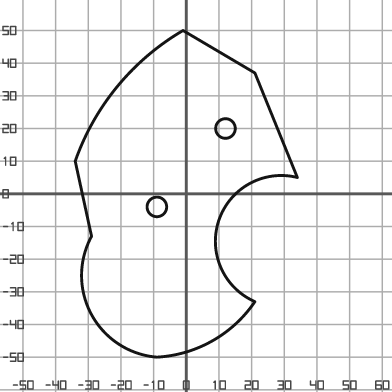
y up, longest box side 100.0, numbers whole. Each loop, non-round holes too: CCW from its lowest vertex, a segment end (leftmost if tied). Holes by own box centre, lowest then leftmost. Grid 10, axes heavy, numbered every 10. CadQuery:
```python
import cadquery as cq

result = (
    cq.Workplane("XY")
    .moveTo(-9.0, -50.0)
    .threePointArc((8.0, -45.0), (21.0, -33.0))
    .threePointArc((10.0, -8.0), (34.0, 5.0))
    .lineTo(21.0, 37.0)
    .lineTo(-1.0, 50.0)
    .threePointArc((-21.0, 33.0), (-34.0, 10.0))
    .lineTo(-29.0, -13.0)
    .threePointArc((-29.0, -37.0), (-9.0, -50.0))
    .close()
    .moveTo(-9.0, -4.0)
    .circle(3.0)
    .moveTo(12.0, 20.0)
    .circle(3.0)
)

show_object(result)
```